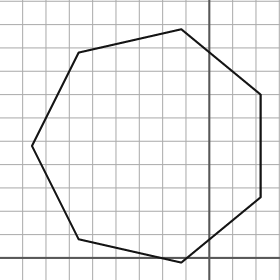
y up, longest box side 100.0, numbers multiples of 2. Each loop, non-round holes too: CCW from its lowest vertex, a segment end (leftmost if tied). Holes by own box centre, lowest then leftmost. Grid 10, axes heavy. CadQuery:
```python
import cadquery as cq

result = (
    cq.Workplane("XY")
    .moveTo(-12.0, -2.0)
    .lineTo(22.0, 26.0)
    .lineTo(22.0, 70.0)
    .lineTo(-12.0, 98.0)
    .lineTo(-56.0, 88.0)
    .lineTo(-76.0, 48.0)
    .lineTo(-56.0, 8.0)
    .close()
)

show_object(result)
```